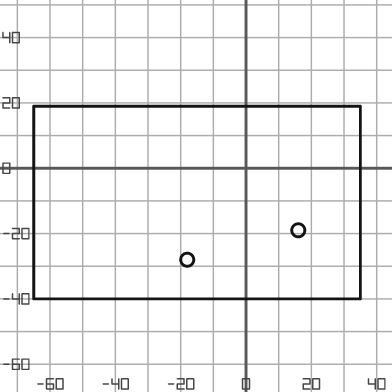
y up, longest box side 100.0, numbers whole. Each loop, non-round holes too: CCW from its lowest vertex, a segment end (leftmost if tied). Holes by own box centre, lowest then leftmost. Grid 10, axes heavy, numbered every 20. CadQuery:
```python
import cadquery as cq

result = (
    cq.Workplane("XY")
    .moveTo(-65.0, -40.0)
    .lineTo(35.0, -40.0)
    .lineTo(35.0, 19.0)
    .lineTo(-65.0, 19.0)
    .close()
    .moveTo(-18.0, -28.0)
    .circle(2.0)
    .moveTo(16.0, -19.0)
    .circle(2.0)
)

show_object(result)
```